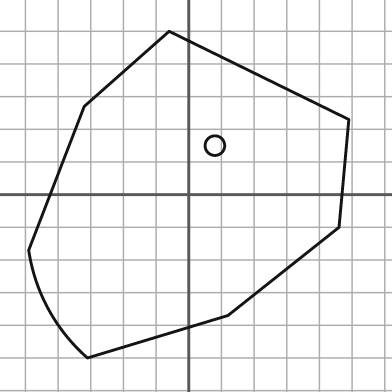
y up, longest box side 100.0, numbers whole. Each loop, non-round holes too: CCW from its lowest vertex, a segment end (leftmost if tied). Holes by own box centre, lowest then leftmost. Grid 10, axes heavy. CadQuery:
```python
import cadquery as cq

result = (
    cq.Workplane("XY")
    .moveTo(-31.0, -50.0)
    .lineTo(12.0, -37.0)
    .lineTo(46.0, -10.0)
    .lineTo(49.0, 23.0)
    .lineTo(-6.0, 50.0)
    .lineTo(-32.0, 27.0)
    .lineTo(-49.0, -17.0)
    .threePointArc((-43.0, -35.0), (-31.0, -50.0))
    .close()
    .moveTo(8.0, 15.0)
    .circle(3.0)
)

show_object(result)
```